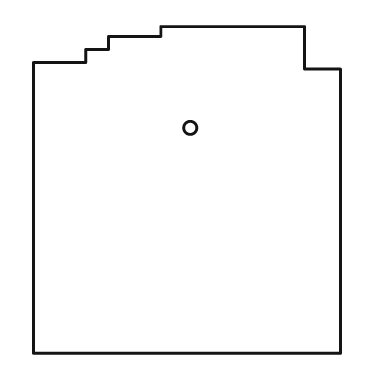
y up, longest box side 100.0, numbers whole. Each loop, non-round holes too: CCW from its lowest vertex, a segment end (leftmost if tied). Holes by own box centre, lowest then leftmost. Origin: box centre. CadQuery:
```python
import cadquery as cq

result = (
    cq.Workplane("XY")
    .moveTo(-47.0, -50.0)
    .lineTo(47.0, -50.0)
    .lineTo(47.0, 37.0)
    .lineTo(36.0, 37.0)
    .lineTo(36.0, 50.0)
    .lineTo(-8.0, 50.0)
    .lineTo(-8.0, 47.0)
    .lineTo(-24.0, 47.0)
    .lineTo(-24.0, 43.0)
    .lineTo(-31.0, 43.0)
    .lineTo(-31.0, 39.0)
    .lineTo(-47.0, 39.0)
    .close()
    .moveTo(1.0, 19.0)
    .circle(2.0)
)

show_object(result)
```